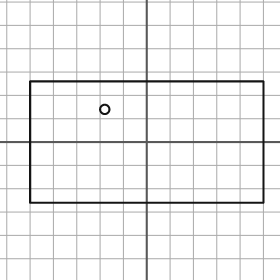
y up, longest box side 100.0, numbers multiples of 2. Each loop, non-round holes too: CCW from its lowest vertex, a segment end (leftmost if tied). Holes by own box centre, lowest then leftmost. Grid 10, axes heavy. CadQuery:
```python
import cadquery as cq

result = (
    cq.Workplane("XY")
    .moveTo(-50.0, -26.0)
    .lineTo(50.0, -26.0)
    .lineTo(50.0, 26.0)
    .lineTo(-50.0, 26.0)
    .close()
    .moveTo(-18.0, 14.0)
    .circle(2.0)
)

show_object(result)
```